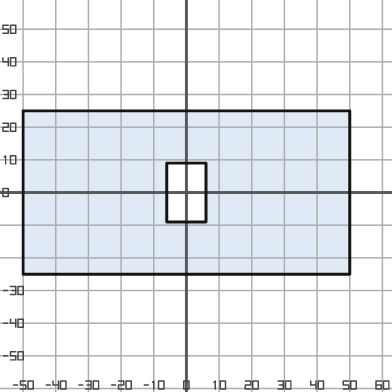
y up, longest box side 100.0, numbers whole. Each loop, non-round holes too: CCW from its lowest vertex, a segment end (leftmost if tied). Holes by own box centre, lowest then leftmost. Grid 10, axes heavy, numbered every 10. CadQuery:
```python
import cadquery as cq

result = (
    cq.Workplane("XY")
    .moveTo(-50.0, -25.0)
    .lineTo(50.0, -25.0)
    .lineTo(50.0, 25.0)
    .lineTo(-50.0, 25.0)
    .close()
    .moveTo(-6.0, -9.0)
    .lineTo(6.0, -9.0)
    .lineTo(6.0, 9.0)
    .lineTo(-6.0, 9.0)
    .close()
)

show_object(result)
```